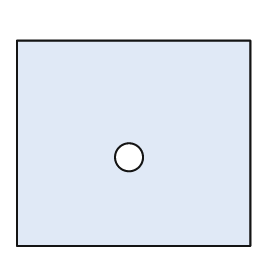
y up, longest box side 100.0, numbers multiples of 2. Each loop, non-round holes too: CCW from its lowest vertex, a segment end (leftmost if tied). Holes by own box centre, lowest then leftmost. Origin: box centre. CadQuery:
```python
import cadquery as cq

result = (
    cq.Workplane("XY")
    .moveTo(-50.0, -44.0)
    .lineTo(50.0, -44.0)
    .lineTo(50.0, 44.0)
    .lineTo(-50.0, 44.0)
    .close()
    .moveTo(-2.0, -6.0)
    .circle(6.0)
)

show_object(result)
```